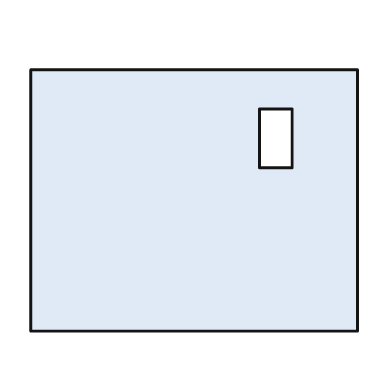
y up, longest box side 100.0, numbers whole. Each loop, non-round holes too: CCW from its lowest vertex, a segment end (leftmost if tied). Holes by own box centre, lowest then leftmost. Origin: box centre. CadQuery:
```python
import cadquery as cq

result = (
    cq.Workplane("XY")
    .moveTo(-50.0, -40.0)
    .lineTo(50.0, -40.0)
    .lineTo(50.0, 40.0)
    .lineTo(-50.0, 40.0)
    .close()
    .moveTo(20.0, 10.0)
    .lineTo(30.0, 10.0)
    .lineTo(30.0, 28.0)
    .lineTo(20.0, 28.0)
    .close()
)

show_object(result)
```